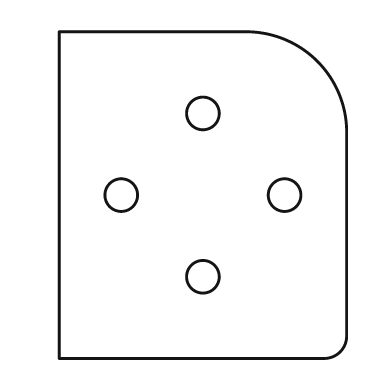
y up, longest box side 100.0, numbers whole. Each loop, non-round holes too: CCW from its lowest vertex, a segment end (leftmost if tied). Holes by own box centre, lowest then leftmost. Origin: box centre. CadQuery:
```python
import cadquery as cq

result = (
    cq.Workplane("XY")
    .moveTo(-44.0, -50.0)
    .lineTo(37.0, -50.0)
    .threePointArc((42.0, -48.0), (44.0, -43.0))
    .lineTo(44.0, 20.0)
    .threePointArc((35.0, 41.0), (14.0, 50.0))
    .lineTo(-44.0, 50.0)
    .close()
    .moveTo(0.0, -25.0)
    .circle(5.0)
    .moveTo(-25.0, 0.0)
    .circle(5.0)
    .moveTo(25.0, 0.0)
    .circle(5.0)
    .moveTo(0.0, 25.0)
    .circle(5.0)
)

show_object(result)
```